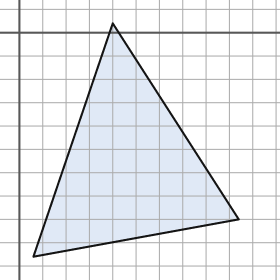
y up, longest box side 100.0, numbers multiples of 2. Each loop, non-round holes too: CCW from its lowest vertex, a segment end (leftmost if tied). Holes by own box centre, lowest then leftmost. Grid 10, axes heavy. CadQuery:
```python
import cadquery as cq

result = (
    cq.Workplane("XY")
    .moveTo(6.0, -96.0)
    .lineTo(94.0, -80.0)
    .lineTo(40.0, 4.0)
    .close()
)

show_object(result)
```